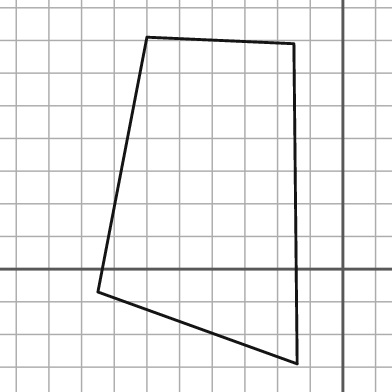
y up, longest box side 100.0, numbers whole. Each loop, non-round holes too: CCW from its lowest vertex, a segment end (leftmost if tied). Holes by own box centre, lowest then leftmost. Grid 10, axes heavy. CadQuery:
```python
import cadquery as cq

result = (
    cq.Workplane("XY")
    .moveTo(-14.0, -29.0)
    .lineTo(-15.0, 69.0)
    .lineTo(-60.0, 71.0)
    .lineTo(-75.0, -7.0)
    .close()
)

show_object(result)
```